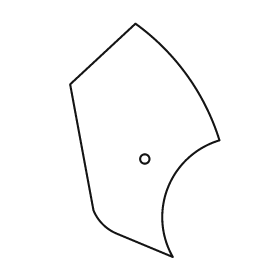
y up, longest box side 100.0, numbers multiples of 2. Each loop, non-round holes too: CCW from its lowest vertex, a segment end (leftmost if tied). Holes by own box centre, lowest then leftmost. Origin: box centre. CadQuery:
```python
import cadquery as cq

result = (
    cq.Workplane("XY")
    .moveTo(12.0, -50.0)
    .threePointArc((10.0, -20.0), (32.0, 0.0))
    .threePointArc((18.0, 28.0), (-4.0, 50.0))
    .lineTo(-32.0, 24.0)
    .lineTo(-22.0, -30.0)
    .threePointArc((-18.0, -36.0), (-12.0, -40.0))
    .close()
    .moveTo(0.0, -8.0)
    .circle(2.0)
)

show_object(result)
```